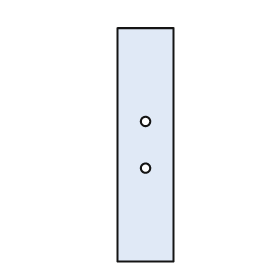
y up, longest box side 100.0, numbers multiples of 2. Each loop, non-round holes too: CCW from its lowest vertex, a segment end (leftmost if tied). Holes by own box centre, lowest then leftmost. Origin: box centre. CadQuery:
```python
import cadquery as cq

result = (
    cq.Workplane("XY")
    .moveTo(-12.0, -50.0)
    .lineTo(12.0, -50.0)
    .lineTo(12.0, 50.0)
    .lineTo(-12.0, 50.0)
    .close()
    .moveTo(0.0, -10.0)
    .circle(2.0)
    .moveTo(0.0, 10.0)
    .circle(2.0)
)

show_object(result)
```